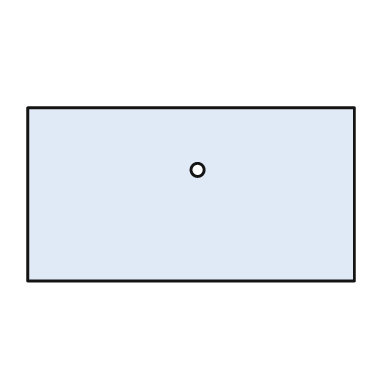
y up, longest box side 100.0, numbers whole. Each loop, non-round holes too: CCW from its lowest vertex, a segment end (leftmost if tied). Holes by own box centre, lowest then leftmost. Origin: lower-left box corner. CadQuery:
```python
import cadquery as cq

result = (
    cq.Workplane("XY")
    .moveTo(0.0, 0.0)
    .lineTo(100.0, 0.0)
    .lineTo(100.0, 53.0)
    .lineTo(0.0, 53.0)
    .close()
    .moveTo(52.0, 34.0)
    .circle(2.0)
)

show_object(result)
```